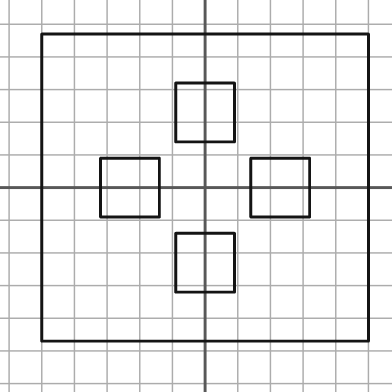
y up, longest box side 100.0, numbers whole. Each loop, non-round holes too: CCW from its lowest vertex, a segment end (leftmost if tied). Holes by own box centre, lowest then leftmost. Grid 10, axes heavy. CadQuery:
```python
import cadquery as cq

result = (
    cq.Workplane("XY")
    .moveTo(-50.0, -47.0)
    .lineTo(50.0, -47.0)
    .lineTo(50.0, 47.0)
    .lineTo(-50.0, 47.0)
    .close()
    .moveTo(-9.0, -32.0)
    .lineTo(9.0, -32.0)
    .lineTo(9.0, -14.0)
    .lineTo(-9.0, -14.0)
    .close()
    .moveTo(-32.0, -9.0)
    .lineTo(-14.0, -9.0)
    .lineTo(-14.0, 9.0)
    .lineTo(-32.0, 9.0)
    .close()
    .moveTo(14.0, -9.0)
    .lineTo(32.0, -9.0)
    .lineTo(32.0, 9.0)
    .lineTo(14.0, 9.0)
    .close()
    .moveTo(-9.0, 14.0)
    .lineTo(9.0, 14.0)
    .lineTo(9.0, 32.0)
    .lineTo(-9.0, 32.0)
    .close()
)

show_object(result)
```